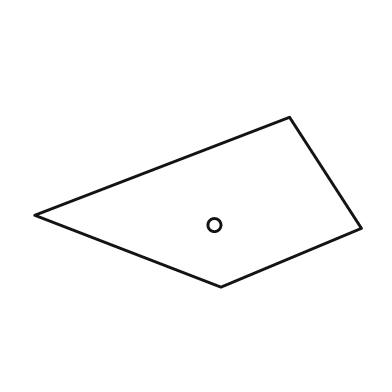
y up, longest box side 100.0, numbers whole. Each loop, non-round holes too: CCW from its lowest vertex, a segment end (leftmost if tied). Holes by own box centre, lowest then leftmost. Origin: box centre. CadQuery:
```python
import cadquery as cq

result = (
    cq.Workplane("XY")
    .moveTo(7.0, -26.0)
    .lineTo(50.0, -8.0)
    .lineTo(28.0, 26.0)
    .lineTo(-50.0, -4.0)
    .close()
    .moveTo(5.0, -7.0)
    .circle(2.0)
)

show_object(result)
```